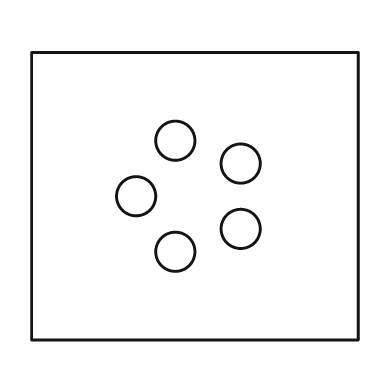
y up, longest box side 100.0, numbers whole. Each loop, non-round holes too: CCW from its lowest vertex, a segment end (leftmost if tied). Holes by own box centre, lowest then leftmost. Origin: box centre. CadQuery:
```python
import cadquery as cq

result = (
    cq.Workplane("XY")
    .moveTo(-50.0, -44.0)
    .lineTo(50.0, -44.0)
    .lineTo(50.0, 44.0)
    .lineTo(-50.0, 44.0)
    .close()
    .moveTo(-6.0, -17.0)
    .circle(6.0)
    .moveTo(14.0, -10.0)
    .circle(6.0)
    .moveTo(-18.0, 0.0)
    .circle(6.0)
    .moveTo(14.0, 10.0)
    .circle(6.0)
    .moveTo(-6.0, 17.0)
    .circle(6.0)
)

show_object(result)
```